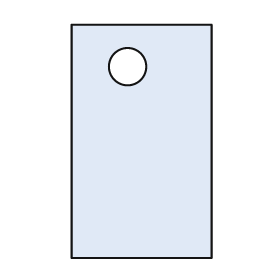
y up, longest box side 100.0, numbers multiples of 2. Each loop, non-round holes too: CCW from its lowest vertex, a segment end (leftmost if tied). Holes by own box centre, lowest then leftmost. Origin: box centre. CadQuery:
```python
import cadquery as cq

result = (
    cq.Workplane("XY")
    .moveTo(-30.0, -50.0)
    .lineTo(30.0, -50.0)
    .lineTo(30.0, 50.0)
    .lineTo(-30.0, 50.0)
    .close()
    .moveTo(-6.0, 32.0)
    .circle(8.0)
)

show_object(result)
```